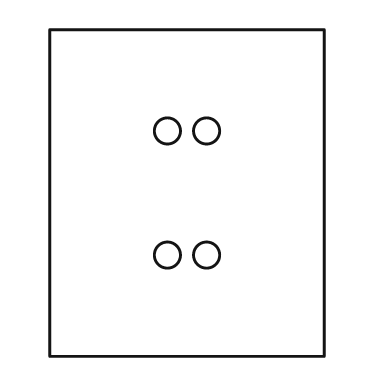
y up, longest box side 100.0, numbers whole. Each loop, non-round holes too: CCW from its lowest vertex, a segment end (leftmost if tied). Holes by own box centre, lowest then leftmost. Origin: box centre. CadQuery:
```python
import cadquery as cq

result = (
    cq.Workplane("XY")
    .moveTo(-42.0, -50.0)
    .lineTo(42.0, -50.0)
    .lineTo(42.0, 50.0)
    .lineTo(-42.0, 50.0)
    .close()
    .moveTo(-6.0, -19.0)
    .circle(4.0)
    .moveTo(6.0, -19.0)
    .circle(4.0)
    .moveTo(-6.0, 19.0)
    .circle(4.0)
    .moveTo(6.0, 19.0)
    .circle(4.0)
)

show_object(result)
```